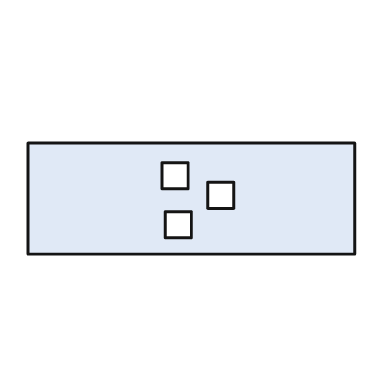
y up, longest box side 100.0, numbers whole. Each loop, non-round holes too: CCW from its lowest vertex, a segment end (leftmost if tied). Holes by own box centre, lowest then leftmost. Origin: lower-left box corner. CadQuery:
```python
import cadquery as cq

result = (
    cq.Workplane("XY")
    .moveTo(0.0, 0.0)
    .lineTo(100.0, 0.0)
    .lineTo(100.0, 34.0)
    .lineTo(0.0, 34.0)
    .close()
    .moveTo(42.0, 5.0)
    .lineTo(50.0, 5.0)
    .lineTo(50.0, 13.0)
    .lineTo(42.0, 13.0)
    .close()
    .moveTo(55.0, 14.0)
    .lineTo(63.0, 14.0)
    .lineTo(63.0, 22.0)
    .lineTo(55.0, 22.0)
    .close()
    .moveTo(41.0, 20.0)
    .lineTo(49.0, 20.0)
    .lineTo(49.0, 28.0)
    .lineTo(41.0, 28.0)
    .close()
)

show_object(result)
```